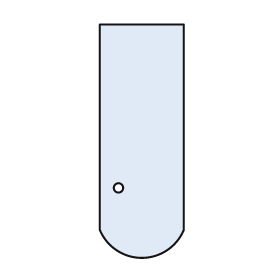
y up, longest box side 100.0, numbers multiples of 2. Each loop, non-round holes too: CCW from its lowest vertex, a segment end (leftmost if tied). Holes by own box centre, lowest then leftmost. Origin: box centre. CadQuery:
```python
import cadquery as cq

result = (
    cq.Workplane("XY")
    .moveTo(-18.0, -38.0)
    .threePointArc((0.0, -50.0), (18.0, -38.0))
    .lineTo(18.0, 50.0)
    .lineTo(-18.0, 50.0)
    .close()
    .moveTo(-10.0, -20.0)
    .circle(2.0)
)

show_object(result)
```